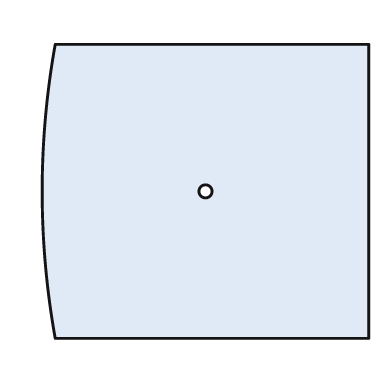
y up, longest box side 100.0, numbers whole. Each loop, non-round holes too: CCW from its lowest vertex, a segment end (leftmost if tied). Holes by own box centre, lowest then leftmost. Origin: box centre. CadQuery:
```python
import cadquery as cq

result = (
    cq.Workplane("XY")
    .moveTo(-46.0, -45.0)
    .lineTo(50.0, -45.0)
    .lineTo(50.0, 45.0)
    .lineTo(-46.0, 45.0)
    .threePointArc((-50.0, 0.0), (-46.0, -45.0))
    .close()
    .moveTo(0.0, 0.0)
    .circle(2.0)
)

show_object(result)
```